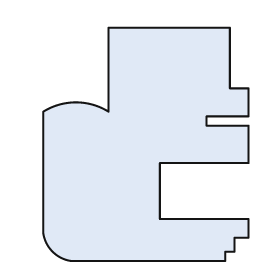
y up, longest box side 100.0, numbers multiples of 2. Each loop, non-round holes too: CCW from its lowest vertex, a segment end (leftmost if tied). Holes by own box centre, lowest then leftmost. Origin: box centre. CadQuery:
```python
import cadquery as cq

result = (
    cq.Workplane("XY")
    .moveTo(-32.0, -50.0)
    .lineTo(34.0, -50.0)
    .lineTo(34.0, -46.0)
    .lineTo(38.0, -46.0)
    .lineTo(38.0, -40.0)
    .lineTo(44.0, -40.0)
    .lineTo(44.0, -32.0)
    .lineTo(6.0, -32.0)
    .lineTo(6.0, -8.0)
    .lineTo(44.0, -8.0)
    .lineTo(44.0, 8.0)
    .lineTo(26.0, 8.0)
    .lineTo(26.0, 12.0)
    .lineTo(44.0, 12.0)
    .lineTo(44.0, 24.0)
    .lineTo(36.0, 24.0)
    .lineTo(36.0, 50.0)
    .lineTo(-16.0, 50.0)
    .lineTo(-16.0, 14.0)
    .threePointArc((-30.0, 18.0), (-44.0, 14.0))
    .lineTo(-44.0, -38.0)
    .threePointArc((-40.0, -46.0), (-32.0, -50.0))
    .close()
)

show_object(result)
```